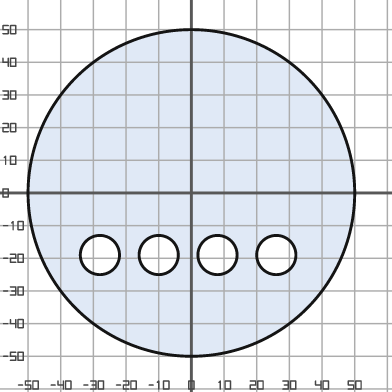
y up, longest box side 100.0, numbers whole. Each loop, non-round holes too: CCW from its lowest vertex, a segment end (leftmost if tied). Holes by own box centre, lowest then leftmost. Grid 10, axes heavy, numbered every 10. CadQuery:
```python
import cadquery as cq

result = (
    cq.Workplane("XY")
    .moveTo(0.0, 0.0)
    .circle(50.0)
    .moveTo(-28.0, -19.0)
    .circle(6.0)
    .moveTo(-10.0, -19.0)
    .circle(6.0)
    .moveTo(8.0, -19.0)
    .circle(6.0)
    .moveTo(26.0, -19.0)
    .circle(6.0)
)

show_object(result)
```